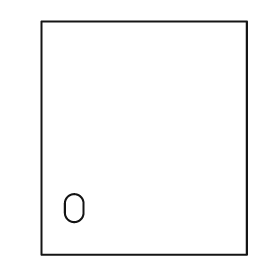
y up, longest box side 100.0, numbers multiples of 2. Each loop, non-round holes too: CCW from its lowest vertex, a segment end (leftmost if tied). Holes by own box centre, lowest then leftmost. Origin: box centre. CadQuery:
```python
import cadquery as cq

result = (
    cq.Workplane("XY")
    .moveTo(-44.0, -50.0)
    .lineTo(44.0, -50.0)
    .lineTo(44.0, 50.0)
    .lineTo(-44.0, 50.0)
    .close()
    .moveTo(-34.0, -32.0)
    .threePointArc((-30.0, -36.0), (-26.0, -32.0))
    .lineTo(-26.0, -28.0)
    .threePointArc((-30.0, -24.0), (-34.0, -28.0))
    .close()
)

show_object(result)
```